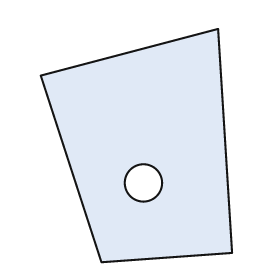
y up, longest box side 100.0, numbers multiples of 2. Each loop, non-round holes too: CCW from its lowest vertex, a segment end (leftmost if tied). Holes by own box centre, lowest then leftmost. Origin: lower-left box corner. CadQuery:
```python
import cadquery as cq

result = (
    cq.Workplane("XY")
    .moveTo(26.0, 0.0)
    .lineTo(82.0, 4.0)
    .lineTo(76.0, 100.0)
    .lineTo(0.0, 80.0)
    .close()
    .moveTo(44.0, 34.0)
    .circle(8.0)
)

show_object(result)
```